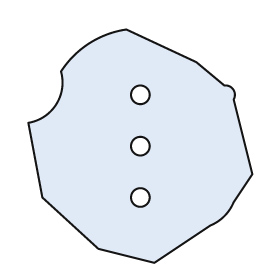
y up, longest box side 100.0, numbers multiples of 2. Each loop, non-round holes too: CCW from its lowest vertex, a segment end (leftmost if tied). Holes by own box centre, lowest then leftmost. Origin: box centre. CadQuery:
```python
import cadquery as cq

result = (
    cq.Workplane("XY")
    .moveTo(6.0, -50.0)
    .lineTo(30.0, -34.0)
    .threePointArc((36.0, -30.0), (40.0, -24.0))
    .lineTo(48.0, -12.0)
    .lineTo(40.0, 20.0)
    .threePointArc((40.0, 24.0), (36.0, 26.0))
    .lineTo(24.0, 36.0)
    .lineTo(-6.0, 50.0)
    .threePointArc((-22.0, 44.0), (-34.0, 32.0))
    .threePointArc((-36.0, 18.0), (-48.0, 10.0))
    .lineTo(-42.0, -22.0)
    .lineTo(-18.0, -44.0)
    .close()
    .moveTo(0.0, -22.0)
    .circle(4.0)
    .moveTo(0.0, 0.0)
    .circle(4.0)
    .moveTo(0.0, 22.0)
    .circle(4.0)
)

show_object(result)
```